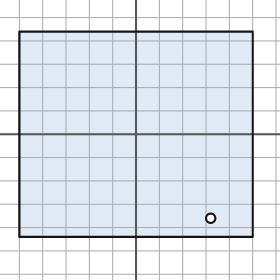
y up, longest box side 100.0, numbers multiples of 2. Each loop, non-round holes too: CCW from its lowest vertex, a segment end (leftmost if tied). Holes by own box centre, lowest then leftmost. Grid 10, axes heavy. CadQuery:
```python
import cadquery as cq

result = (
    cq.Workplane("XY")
    .moveTo(-50.0, -44.0)
    .lineTo(50.0, -44.0)
    .lineTo(50.0, 44.0)
    .lineTo(-50.0, 44.0)
    .close()
    .moveTo(32.0, -36.0)
    .circle(2.0)
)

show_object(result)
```